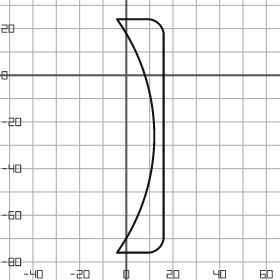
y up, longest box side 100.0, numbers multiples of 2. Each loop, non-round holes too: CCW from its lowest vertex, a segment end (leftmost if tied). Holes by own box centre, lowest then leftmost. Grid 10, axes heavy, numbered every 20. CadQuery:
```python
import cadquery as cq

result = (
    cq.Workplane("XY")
    .moveTo(-4.0, -76.0)
    .lineTo(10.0, -76.0)
    .threePointArc((14.0, -74.0), (16.0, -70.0))
    .lineTo(16.0, 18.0)
    .threePointArc((14.0, 22.0), (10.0, 24.0))
    .lineTo(-4.0, 24.0)
    .threePointArc((12.0, -26.0), (-4.0, -76.0))
    .close()
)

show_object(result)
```